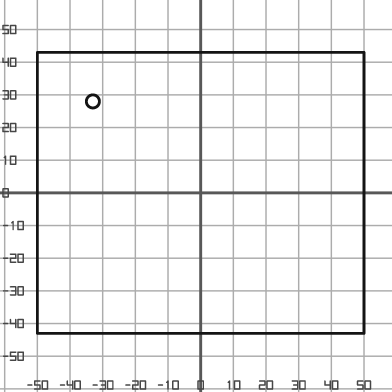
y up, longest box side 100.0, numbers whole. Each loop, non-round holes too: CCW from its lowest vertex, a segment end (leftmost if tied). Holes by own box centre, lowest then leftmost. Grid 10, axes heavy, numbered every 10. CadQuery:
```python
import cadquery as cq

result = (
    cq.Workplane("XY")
    .moveTo(-50.0, -43.0)
    .lineTo(50.0, -43.0)
    .lineTo(50.0, 43.0)
    .lineTo(-50.0, 43.0)
    .close()
    .moveTo(-33.0, 28.0)
    .circle(2.0)
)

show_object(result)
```